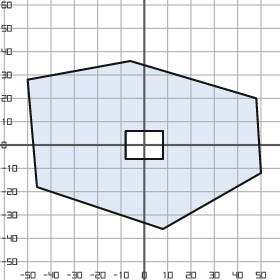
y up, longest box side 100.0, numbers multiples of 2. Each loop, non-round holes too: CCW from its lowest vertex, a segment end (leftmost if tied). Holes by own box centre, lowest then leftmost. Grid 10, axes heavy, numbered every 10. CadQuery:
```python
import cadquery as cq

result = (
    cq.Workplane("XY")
    .moveTo(8.0, -36.0)
    .lineTo(50.0, -12.0)
    .lineTo(48.0, 20.0)
    .lineTo(-6.0, 36.0)
    .lineTo(-50.0, 28.0)
    .lineTo(-46.0, -18.0)
    .close()
    .moveTo(-8.0, -6.0)
    .lineTo(8.0, -6.0)
    .lineTo(8.0, 6.0)
    .lineTo(-8.0, 6.0)
    .close()
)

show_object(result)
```